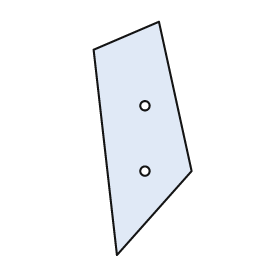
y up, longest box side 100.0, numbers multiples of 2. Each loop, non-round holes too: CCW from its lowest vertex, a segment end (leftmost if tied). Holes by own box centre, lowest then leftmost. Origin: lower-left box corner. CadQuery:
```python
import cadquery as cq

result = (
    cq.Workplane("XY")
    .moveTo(10.0, 0.0)
    .lineTo(42.0, 36.0)
    .lineTo(28.0, 100.0)
    .lineTo(0.0, 88.0)
    .close()
    .moveTo(22.0, 36.0)
    .circle(2.0)
    .moveTo(22.0, 64.0)
    .circle(2.0)
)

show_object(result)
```